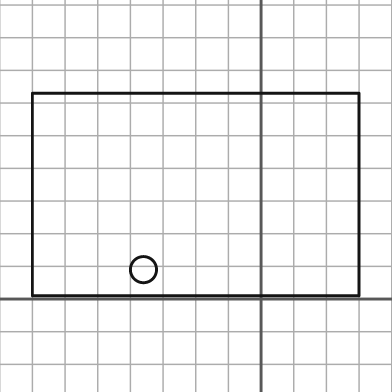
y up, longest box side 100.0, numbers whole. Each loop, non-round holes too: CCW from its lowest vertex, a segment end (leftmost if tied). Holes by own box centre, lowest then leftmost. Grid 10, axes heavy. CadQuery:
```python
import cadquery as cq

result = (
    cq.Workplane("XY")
    .moveTo(-70.0, 1.0)
    .lineTo(30.0, 1.0)
    .lineTo(30.0, 63.0)
    .lineTo(-70.0, 63.0)
    .close()
    .moveTo(-36.0, 9.0)
    .circle(4.0)
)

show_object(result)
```